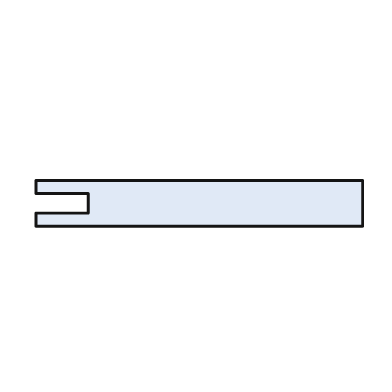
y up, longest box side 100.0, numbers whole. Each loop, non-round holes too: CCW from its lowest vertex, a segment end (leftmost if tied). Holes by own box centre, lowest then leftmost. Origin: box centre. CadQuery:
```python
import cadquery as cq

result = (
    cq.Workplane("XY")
    .moveTo(-50.0, -7.0)
    .lineTo(50.0, -7.0)
    .lineTo(50.0, 7.0)
    .lineTo(-50.0, 7.0)
    .lineTo(-50.0, 3.0)
    .lineTo(-34.0, 3.0)
    .lineTo(-34.0, -3.0)
    .lineTo(-50.0, -3.0)
    .close()
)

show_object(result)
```